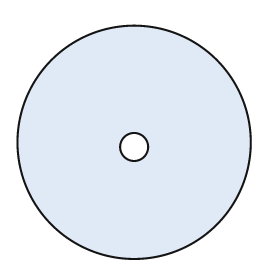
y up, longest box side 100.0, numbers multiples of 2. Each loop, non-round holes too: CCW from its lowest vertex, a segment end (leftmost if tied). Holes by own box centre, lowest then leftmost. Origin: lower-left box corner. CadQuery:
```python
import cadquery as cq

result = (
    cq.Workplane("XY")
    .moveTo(50.0, 50.0)
    .circle(50.0)
    .moveTo(50.0, 48.0)
    .circle(6.0)
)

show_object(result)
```